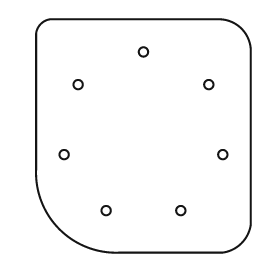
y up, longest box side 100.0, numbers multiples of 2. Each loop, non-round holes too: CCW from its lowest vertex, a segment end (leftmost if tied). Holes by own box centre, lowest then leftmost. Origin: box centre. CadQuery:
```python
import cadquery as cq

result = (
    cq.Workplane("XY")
    .moveTo(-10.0, -50.0)
    .lineTo(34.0, -50.0)
    .threePointArc((42.0, -46.0), (46.0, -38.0))
    .lineTo(46.0, 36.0)
    .threePointArc((42.0, 46.0), (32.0, 50.0))
    .lineTo(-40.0, 50.0)
    .threePointArc((-44.0, 48.0), (-46.0, 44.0))
    .lineTo(-46.0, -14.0)
    .threePointArc((-36.0, -40.0), (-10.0, -50.0))
    .close()
    .moveTo(-16.0, -32.0)
    .circle(2.0)
    .moveTo(16.0, -32.0)
    .circle(2.0)
    .moveTo(-34.0, -8.0)
    .circle(2.0)
    .moveTo(34.0, -8.0)
    .circle(2.0)
    .moveTo(-28.0, 22.0)
    .circle(2.0)
    .moveTo(28.0, 22.0)
    .circle(2.0)
    .moveTo(0.0, 36.0)
    .circle(2.0)
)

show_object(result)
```